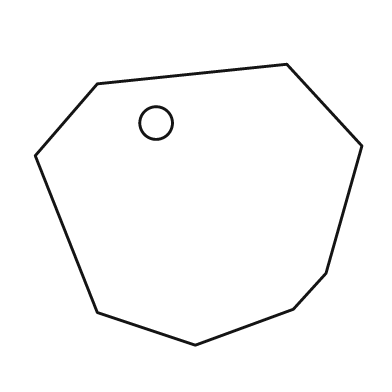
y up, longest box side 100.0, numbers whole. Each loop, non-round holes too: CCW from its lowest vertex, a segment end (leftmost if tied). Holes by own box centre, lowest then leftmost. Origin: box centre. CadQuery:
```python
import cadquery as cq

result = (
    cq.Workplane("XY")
    .moveTo(-1.0, -43.0)
    .lineTo(29.0, -32.0)
    .lineTo(39.0, -21.0)
    .lineTo(50.0, 18.0)
    .lineTo(27.0, 43.0)
    .lineTo(-31.0, 37.0)
    .lineTo(-50.0, 15.0)
    .lineTo(-31.0, -33.0)
    .close()
    .moveTo(-13.0, 25.0)
    .circle(5.0)
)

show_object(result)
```